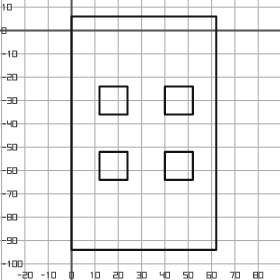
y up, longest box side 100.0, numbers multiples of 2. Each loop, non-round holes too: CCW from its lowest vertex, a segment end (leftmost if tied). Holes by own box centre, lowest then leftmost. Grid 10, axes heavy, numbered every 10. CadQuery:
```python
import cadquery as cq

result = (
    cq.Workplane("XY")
    .moveTo(0.0, -94.0)
    .lineTo(62.0, -94.0)
    .lineTo(62.0, 6.0)
    .lineTo(0.0, 6.0)
    .close()
    .moveTo(12.0, -64.0)
    .lineTo(24.0, -64.0)
    .lineTo(24.0, -52.0)
    .lineTo(12.0, -52.0)
    .close()
    .moveTo(40.0, -64.0)
    .lineTo(52.0, -64.0)
    .lineTo(52.0, -52.0)
    .lineTo(40.0, -52.0)
    .close()
    .moveTo(12.0, -36.0)
    .lineTo(24.0, -36.0)
    .lineTo(24.0, -24.0)
    .lineTo(12.0, -24.0)
    .close()
    .moveTo(40.0, -36.0)
    .lineTo(52.0, -36.0)
    .lineTo(52.0, -24.0)
    .lineTo(40.0, -24.0)
    .close()
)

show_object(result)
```